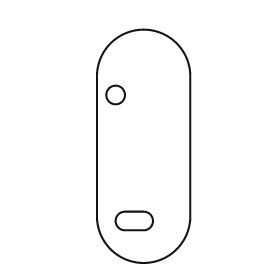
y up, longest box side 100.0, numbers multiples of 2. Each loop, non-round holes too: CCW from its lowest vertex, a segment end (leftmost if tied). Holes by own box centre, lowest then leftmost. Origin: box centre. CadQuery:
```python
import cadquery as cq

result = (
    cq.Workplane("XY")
    .moveTo(-20.0, -30.0)
    .threePointArc((0.0, -50.0), (20.0, -30.0))
    .lineTo(20.0, 30.0)
    .threePointArc((0.0, 50.0), (-20.0, 30.0))
    .close()
    .moveTo(-8.0, -36.0)
    .lineTo(0.0, -36.0)
    .threePointArc((4.0, -32.0), (0.0, -28.0))
    .lineTo(-8.0, -28.0)
    .threePointArc((-12.0, -32.0), (-8.0, -36.0))
    .close()
    .moveTo(-12.0, 22.0)
    .circle(4.0)
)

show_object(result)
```